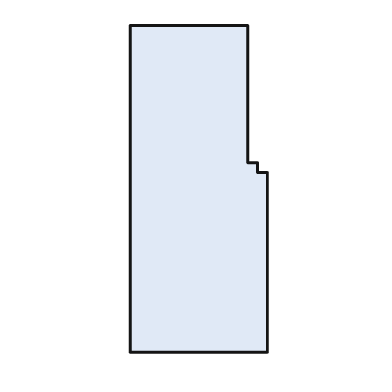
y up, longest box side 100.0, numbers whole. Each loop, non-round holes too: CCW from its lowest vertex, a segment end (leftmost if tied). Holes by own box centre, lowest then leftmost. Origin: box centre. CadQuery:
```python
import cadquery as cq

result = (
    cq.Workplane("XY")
    .moveTo(-21.0, -50.0)
    .lineTo(21.0, -50.0)
    .lineTo(21.0, 5.0)
    .lineTo(18.0, 5.0)
    .lineTo(18.0, 8.0)
    .lineTo(15.0, 8.0)
    .lineTo(15.0, 50.0)
    .lineTo(-21.0, 50.0)
    .close()
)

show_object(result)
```